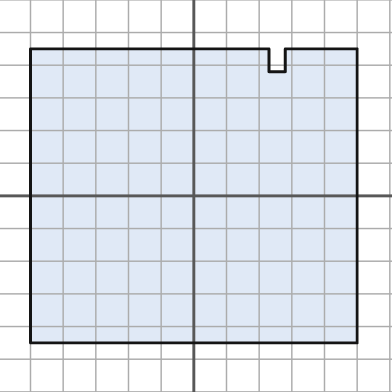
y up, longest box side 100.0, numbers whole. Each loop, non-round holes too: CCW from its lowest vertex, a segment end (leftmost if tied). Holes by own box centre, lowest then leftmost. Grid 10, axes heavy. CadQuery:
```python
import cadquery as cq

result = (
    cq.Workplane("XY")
    .moveTo(-50.0, -45.0)
    .lineTo(50.0, -45.0)
    .lineTo(50.0, 45.0)
    .lineTo(28.0, 45.0)
    .lineTo(28.0, 38.0)
    .lineTo(23.0, 38.0)
    .lineTo(23.0, 45.0)
    .lineTo(-50.0, 45.0)
    .close()
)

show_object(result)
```